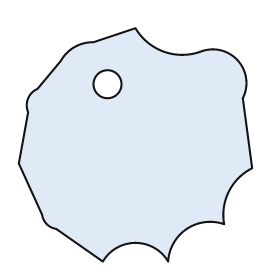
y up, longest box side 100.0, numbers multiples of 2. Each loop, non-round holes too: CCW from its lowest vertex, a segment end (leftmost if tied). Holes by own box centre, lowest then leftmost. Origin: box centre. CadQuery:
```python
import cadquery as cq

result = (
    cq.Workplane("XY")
    .moveTo(-14.0, -50.0)
    .threePointArc((0.0, -42.0), (14.0, -50.0))
    .threePointArc((22.0, -36.0), (38.0, -34.0))
    .threePointArc((40.0, -20.0), (50.0, -10.0))
    .lineTo(46.0, 20.0)
    .threePointArc((44.0, 36.0), (28.0, 40.0))
    .threePointArc((12.0, 40.0), (0.0, 50.0))
    .lineTo(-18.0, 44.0)
    .threePointArc((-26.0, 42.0), (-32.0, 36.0))
    .lineTo(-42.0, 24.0)
    .threePointArc((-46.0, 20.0), (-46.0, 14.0))
    .lineTo(-50.0, -8.0)
    .lineTo(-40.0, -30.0)
    .threePointArc((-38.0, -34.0), (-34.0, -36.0))
    .close()
    .moveTo(-12.0, 26.0)
    .circle(6.0)
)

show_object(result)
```